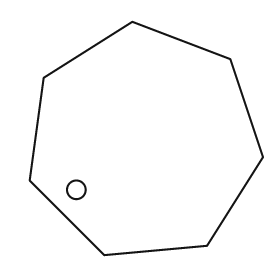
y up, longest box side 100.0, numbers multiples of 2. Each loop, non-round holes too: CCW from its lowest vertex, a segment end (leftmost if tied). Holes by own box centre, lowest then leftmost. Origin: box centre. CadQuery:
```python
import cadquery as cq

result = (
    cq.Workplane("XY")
    .moveTo(-18.0, -50.0)
    .lineTo(26.0, -46.0)
    .lineTo(50.0, -8.0)
    .lineTo(36.0, 34.0)
    .lineTo(-6.0, 50.0)
    .lineTo(-44.0, 26.0)
    .lineTo(-50.0, -18.0)
    .close()
    .moveTo(-30.0, -22.0)
    .circle(4.0)
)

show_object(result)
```